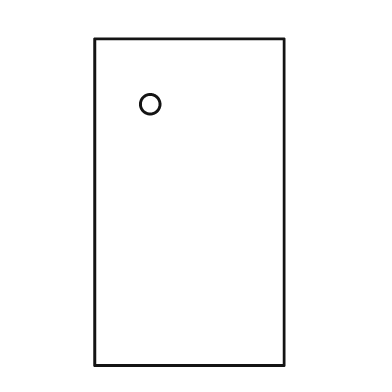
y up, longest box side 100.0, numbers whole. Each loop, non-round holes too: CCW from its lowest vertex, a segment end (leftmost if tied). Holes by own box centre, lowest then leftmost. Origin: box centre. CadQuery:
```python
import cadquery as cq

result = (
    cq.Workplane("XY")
    .moveTo(-29.0, -50.0)
    .lineTo(29.0, -50.0)
    .lineTo(29.0, 50.0)
    .lineTo(-29.0, 50.0)
    .close()
    .moveTo(-12.0, 30.0)
    .circle(3.0)
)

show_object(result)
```